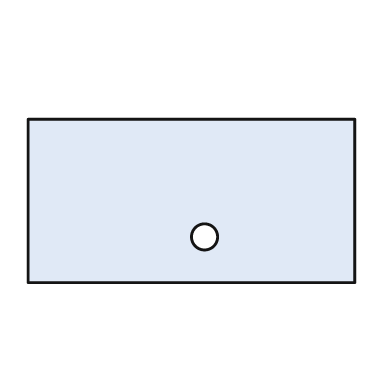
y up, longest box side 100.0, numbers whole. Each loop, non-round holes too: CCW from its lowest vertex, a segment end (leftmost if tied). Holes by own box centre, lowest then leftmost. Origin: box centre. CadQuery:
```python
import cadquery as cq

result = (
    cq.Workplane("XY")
    .moveTo(-50.0, -25.0)
    .lineTo(50.0, -25.0)
    .lineTo(50.0, 25.0)
    .lineTo(-50.0, 25.0)
    .close()
    .moveTo(4.0, -11.0)
    .circle(4.0)
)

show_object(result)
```